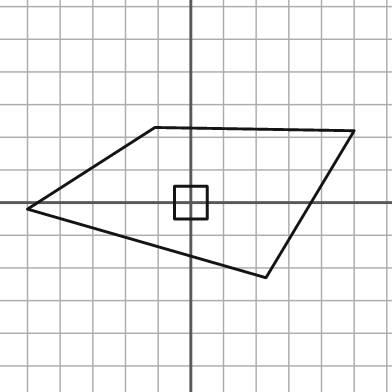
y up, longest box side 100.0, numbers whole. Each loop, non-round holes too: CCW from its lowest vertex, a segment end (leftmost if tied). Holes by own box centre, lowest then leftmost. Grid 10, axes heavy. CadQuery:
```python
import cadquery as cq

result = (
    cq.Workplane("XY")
    .moveTo(23.0, -23.0)
    .lineTo(50.0, 22.0)
    .lineTo(-11.0, 23.0)
    .lineTo(-50.0, -2.0)
    .close()
    .moveTo(-5.0, -5.0)
    .lineTo(5.0, -5.0)
    .lineTo(5.0, 5.0)
    .lineTo(-5.0, 5.0)
    .close()
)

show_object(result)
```